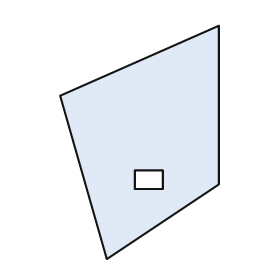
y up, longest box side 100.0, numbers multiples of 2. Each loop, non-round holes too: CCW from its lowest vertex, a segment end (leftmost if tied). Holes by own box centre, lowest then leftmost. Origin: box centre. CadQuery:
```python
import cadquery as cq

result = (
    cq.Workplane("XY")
    .moveTo(-14.0, -50.0)
    .lineTo(34.0, -18.0)
    .lineTo(34.0, 50.0)
    .lineTo(-34.0, 20.0)
    .close()
    .moveTo(-2.0, -20.0)
    .lineTo(10.0, -20.0)
    .lineTo(10.0, -12.0)
    .lineTo(-2.0, -12.0)
    .close()
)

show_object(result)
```